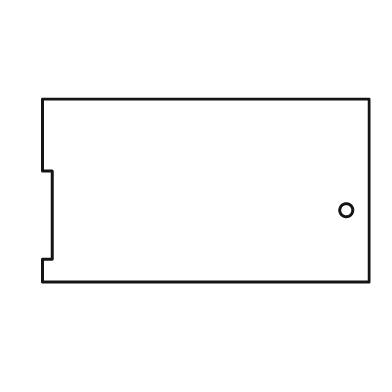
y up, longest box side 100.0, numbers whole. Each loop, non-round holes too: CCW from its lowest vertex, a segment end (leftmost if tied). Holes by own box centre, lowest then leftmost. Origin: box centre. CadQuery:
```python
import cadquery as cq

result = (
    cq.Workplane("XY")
    .moveTo(-50.0, -28.0)
    .lineTo(50.0, -28.0)
    .lineTo(50.0, 28.0)
    .lineTo(-50.0, 28.0)
    .lineTo(-50.0, 6.0)
    .lineTo(-47.0, 6.0)
    .lineTo(-47.0, -21.0)
    .lineTo(-50.0, -21.0)
    .close()
    .moveTo(43.0, -6.0)
    .circle(2.0)
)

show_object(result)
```